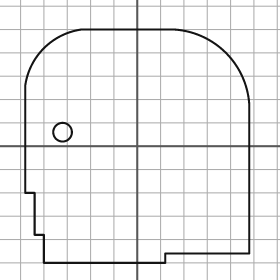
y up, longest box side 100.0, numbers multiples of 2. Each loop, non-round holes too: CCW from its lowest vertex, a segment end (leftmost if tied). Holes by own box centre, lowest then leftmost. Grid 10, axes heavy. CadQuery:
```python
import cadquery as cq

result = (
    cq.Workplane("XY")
    .moveTo(-40.0, -50.0)
    .lineTo(12.0, -50.0)
    .lineTo(12.0, -46.0)
    .lineTo(48.0, -46.0)
    .lineTo(48.0, 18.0)
    .threePointArc((38.0, 40.0), (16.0, 50.0))
    .lineTo(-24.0, 50.0)
    .threePointArc((-40.0, 42.0), (-48.0, 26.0))
    .lineTo(-48.0, -20.0)
    .lineTo(-44.0, -20.0)
    .lineTo(-44.0, -38.0)
    .lineTo(-40.0, -38.0)
    .close()
    .moveTo(-32.0, 6.0)
    .circle(4.0)
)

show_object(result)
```